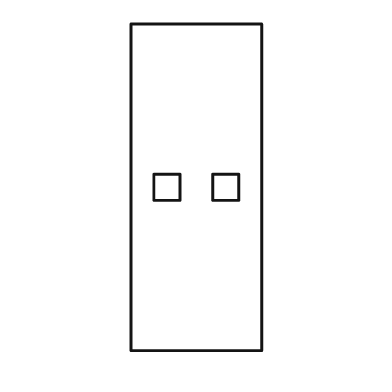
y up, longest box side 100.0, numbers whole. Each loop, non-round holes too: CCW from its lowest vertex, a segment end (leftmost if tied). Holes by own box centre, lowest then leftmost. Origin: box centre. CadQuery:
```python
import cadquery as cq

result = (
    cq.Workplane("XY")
    .moveTo(-20.0, -50.0)
    .lineTo(20.0, -50.0)
    .lineTo(20.0, 50.0)
    .lineTo(-20.0, 50.0)
    .close()
    .moveTo(-13.0, -4.0)
    .lineTo(-5.0, -4.0)
    .lineTo(-5.0, 4.0)
    .lineTo(-13.0, 4.0)
    .close()
    .moveTo(5.0, -4.0)
    .lineTo(13.0, -4.0)
    .lineTo(13.0, 4.0)
    .lineTo(5.0, 4.0)
    .close()
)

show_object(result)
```